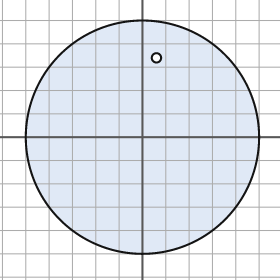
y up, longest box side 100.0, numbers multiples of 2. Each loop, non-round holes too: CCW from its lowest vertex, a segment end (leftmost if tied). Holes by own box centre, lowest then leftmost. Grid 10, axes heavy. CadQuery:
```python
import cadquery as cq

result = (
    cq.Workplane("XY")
    .moveTo(0.0, 0.0)
    .circle(50.0)
    .moveTo(6.0, 34.0)
    .circle(2.0)
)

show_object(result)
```